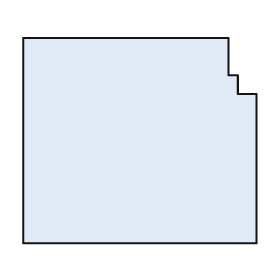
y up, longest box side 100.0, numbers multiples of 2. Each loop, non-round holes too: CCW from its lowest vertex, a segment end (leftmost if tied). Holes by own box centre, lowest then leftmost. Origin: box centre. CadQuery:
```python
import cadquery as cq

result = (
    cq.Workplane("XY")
    .moveTo(-50.0, -44.0)
    .lineTo(50.0, -44.0)
    .lineTo(50.0, 20.0)
    .lineTo(42.0, 20.0)
    .lineTo(42.0, 28.0)
    .lineTo(38.0, 28.0)
    .lineTo(38.0, 44.0)
    .lineTo(-50.0, 44.0)
    .close()
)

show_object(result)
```